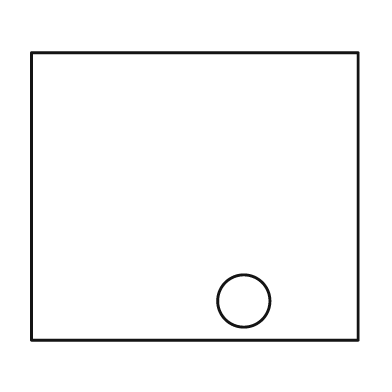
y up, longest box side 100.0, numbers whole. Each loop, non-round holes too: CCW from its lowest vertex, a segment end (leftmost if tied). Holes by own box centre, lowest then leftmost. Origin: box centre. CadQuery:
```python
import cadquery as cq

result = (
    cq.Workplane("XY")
    .moveTo(-50.0, -44.0)
    .lineTo(50.0, -44.0)
    .lineTo(50.0, 44.0)
    .lineTo(-50.0, 44.0)
    .close()
    .moveTo(15.0, -32.0)
    .circle(8.0)
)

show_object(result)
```